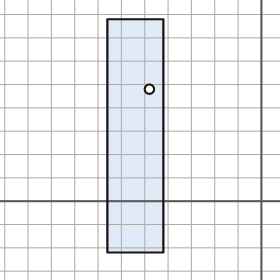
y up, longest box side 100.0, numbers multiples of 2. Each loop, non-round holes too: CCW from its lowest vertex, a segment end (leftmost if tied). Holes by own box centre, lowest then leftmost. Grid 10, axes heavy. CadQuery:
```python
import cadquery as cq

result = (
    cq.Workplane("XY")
    .moveTo(-66.0, -22.0)
    .lineTo(-42.0, -22.0)
    .lineTo(-42.0, 78.0)
    .lineTo(-66.0, 78.0)
    .close()
    .moveTo(-48.0, 48.0)
    .circle(2.0)
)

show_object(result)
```